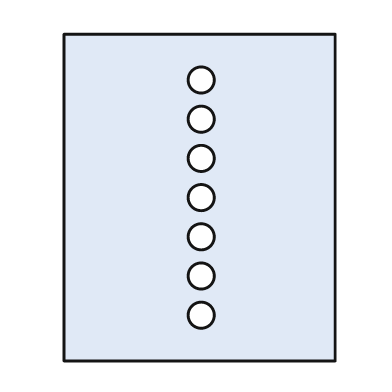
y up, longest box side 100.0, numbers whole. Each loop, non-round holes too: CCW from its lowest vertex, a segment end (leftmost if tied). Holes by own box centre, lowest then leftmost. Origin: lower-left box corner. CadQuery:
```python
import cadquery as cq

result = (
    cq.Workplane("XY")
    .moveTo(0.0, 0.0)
    .lineTo(83.0, 0.0)
    .lineTo(83.0, 100.0)
    .lineTo(0.0, 100.0)
    .close()
    .moveTo(42.0, 14.0)
    .circle(4.0)
    .moveTo(42.0, 26.0)
    .circle(4.0)
    .moveTo(42.0, 38.0)
    .circle(4.0)
    .moveTo(42.0, 50.0)
    .circle(4.0)
    .moveTo(42.0, 62.0)
    .circle(4.0)
    .moveTo(42.0, 74.0)
    .circle(4.0)
    .moveTo(42.0, 86.0)
    .circle(4.0)
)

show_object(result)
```